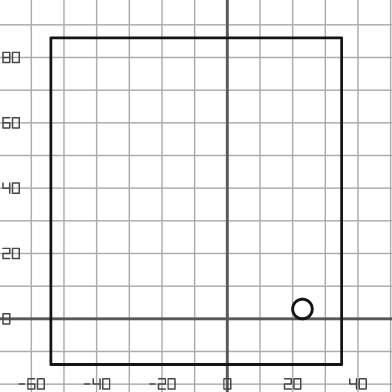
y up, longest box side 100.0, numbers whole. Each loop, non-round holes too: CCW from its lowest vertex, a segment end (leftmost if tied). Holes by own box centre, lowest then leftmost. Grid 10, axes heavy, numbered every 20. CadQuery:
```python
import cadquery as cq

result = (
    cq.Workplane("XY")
    .moveTo(-54.0, -14.0)
    .lineTo(35.0, -14.0)
    .lineTo(35.0, 86.0)
    .lineTo(-54.0, 86.0)
    .close()
    .moveTo(23.0, 3.0)
    .circle(3.0)
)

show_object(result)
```